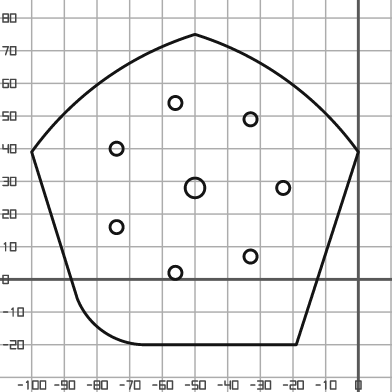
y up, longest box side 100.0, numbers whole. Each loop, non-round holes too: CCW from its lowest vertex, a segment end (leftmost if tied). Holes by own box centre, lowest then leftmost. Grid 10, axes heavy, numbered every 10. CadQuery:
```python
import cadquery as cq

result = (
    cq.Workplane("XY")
    .moveTo(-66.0, -20.0)
    .lineTo(-19.0, -20.0)
    .lineTo(0.0, 39.0)
    .threePointArc((-22.0, 61.0), (-50.0, 75.0))
    .threePointArc((-78.0, 61.0), (-100.0, 39.0))
    .lineTo(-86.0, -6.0)
    .threePointArc((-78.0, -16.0), (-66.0, -20.0))
    .close()
    .moveTo(-56.0, 2.0)
    .circle(2.0)
    .moveTo(-33.0, 7.0)
    .circle(2.0)
    .moveTo(-74.0, 16.0)
    .circle(2.0)
    .moveTo(-50.0, 28.0)
    .circle(3.0)
    .moveTo(-23.0, 28.0)
    .circle(2.0)
    .moveTo(-74.0, 40.0)
    .circle(2.0)
    .moveTo(-33.0, 49.0)
    .circle(2.0)
    .moveTo(-56.0, 54.0)
    .circle(2.0)
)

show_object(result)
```